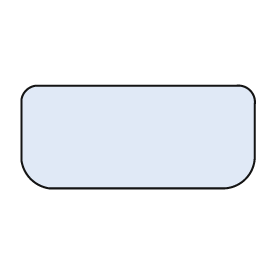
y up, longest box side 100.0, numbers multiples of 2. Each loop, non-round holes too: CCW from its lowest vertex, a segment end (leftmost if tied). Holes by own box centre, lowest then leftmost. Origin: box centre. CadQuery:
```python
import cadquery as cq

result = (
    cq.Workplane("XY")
    .moveTo(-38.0, -22.0)
    .lineTo(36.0, -22.0)
    .threePointArc((46.0, -18.0), (50.0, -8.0))
    .lineTo(50.0, 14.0)
    .threePointArc((48.0, 20.0), (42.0, 22.0))
    .lineTo(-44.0, 22.0)
    .threePointArc((-48.0, 20.0), (-50.0, 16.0))
    .lineTo(-50.0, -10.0)
    .threePointArc((-46.0, -18.0), (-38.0, -22.0))
    .close()
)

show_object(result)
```